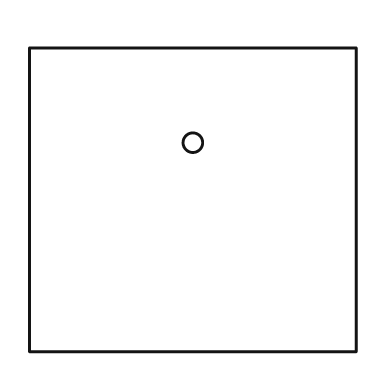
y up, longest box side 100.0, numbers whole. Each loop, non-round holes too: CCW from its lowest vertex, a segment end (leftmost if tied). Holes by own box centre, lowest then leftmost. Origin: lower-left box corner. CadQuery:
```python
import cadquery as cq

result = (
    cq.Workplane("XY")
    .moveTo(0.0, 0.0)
    .lineTo(100.0, 0.0)
    .lineTo(100.0, 93.0)
    .lineTo(0.0, 93.0)
    .close()
    .moveTo(50.0, 64.0)
    .circle(3.0)
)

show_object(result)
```